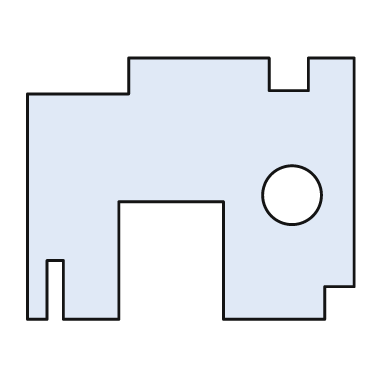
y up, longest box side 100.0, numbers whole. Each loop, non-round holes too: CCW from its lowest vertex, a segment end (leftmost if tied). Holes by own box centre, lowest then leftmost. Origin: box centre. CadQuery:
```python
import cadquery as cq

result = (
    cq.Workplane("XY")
    .moveTo(-50.0, -40.0)
    .lineTo(-44.0, -40.0)
    .lineTo(-44.0, -22.0)
    .lineTo(-39.0, -22.0)
    .lineTo(-39.0, -40.0)
    .lineTo(-22.0, -40.0)
    .lineTo(-22.0, -4.0)
    .lineTo(10.0, -4.0)
    .lineTo(10.0, -40.0)
    .lineTo(41.0, -40.0)
    .lineTo(41.0, -30.0)
    .lineTo(50.0, -30.0)
    .lineTo(50.0, 40.0)
    .lineTo(36.0, 40.0)
    .lineTo(36.0, 30.0)
    .lineTo(24.0, 30.0)
    .lineTo(24.0, 40.0)
    .lineTo(-19.0, 40.0)
    .lineTo(-19.0, 29.0)
    .lineTo(-50.0, 29.0)
    .close()
    .moveTo(31.0, -2.0)
    .circle(9.0)
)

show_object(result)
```